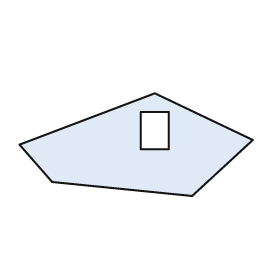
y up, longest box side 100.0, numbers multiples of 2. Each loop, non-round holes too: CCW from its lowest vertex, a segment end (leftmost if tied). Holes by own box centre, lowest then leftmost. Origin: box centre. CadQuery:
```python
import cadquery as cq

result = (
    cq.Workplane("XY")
    .moveTo(24.0, -22.0)
    .lineTo(50.0, 2.0)
    .lineTo(8.0, 22.0)
    .lineTo(-50.0, 0.0)
    .lineTo(-36.0, -16.0)
    .close()
    .moveTo(2.0, -2.0)
    .lineTo(14.0, -2.0)
    .lineTo(14.0, 14.0)
    .lineTo(2.0, 14.0)
    .close()
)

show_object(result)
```